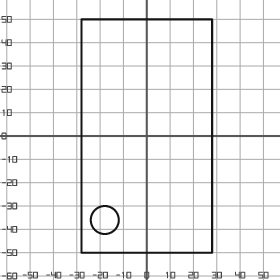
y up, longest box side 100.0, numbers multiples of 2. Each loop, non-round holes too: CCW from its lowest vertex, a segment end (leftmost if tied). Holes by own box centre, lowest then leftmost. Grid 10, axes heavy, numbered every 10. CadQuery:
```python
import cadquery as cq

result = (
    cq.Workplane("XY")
    .moveTo(-28.0, -50.0)
    .lineTo(28.0, -50.0)
    .lineTo(28.0, 50.0)
    .lineTo(-28.0, 50.0)
    .close()
    .moveTo(-18.0, -36.0)
    .circle(6.0)
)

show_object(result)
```